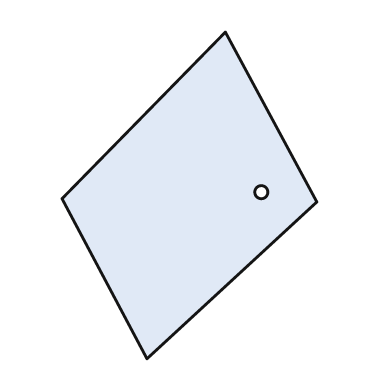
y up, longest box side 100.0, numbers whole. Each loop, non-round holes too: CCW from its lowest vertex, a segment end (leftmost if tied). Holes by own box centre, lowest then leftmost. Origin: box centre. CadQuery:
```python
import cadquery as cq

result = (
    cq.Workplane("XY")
    .moveTo(-13.0, -50.0)
    .lineTo(39.0, -2.0)
    .lineTo(11.0, 50.0)
    .lineTo(-39.0, -1.0)
    .close()
    .moveTo(22.0, 1.0)
    .circle(2.0)
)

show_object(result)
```